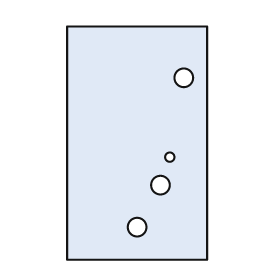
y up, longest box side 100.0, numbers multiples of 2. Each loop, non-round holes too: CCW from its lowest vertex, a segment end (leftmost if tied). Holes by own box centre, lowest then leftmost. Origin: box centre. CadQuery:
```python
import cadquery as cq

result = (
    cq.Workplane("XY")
    .moveTo(-30.0, -50.0)
    .lineTo(30.0, -50.0)
    .lineTo(30.0, 50.0)
    .lineTo(-30.0, 50.0)
    .close()
    .moveTo(0.0, -36.0)
    .circle(4.0)
    .moveTo(10.0, -18.0)
    .circle(4.0)
    .moveTo(14.0, -6.0)
    .circle(2.0)
    .moveTo(20.0, 28.0)
    .circle(4.0)
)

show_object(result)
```